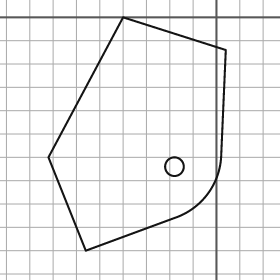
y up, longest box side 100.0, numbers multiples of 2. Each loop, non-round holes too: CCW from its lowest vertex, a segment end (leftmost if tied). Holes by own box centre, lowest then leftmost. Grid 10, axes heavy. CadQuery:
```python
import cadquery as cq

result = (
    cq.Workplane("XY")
    .moveTo(-56.0, -100.0)
    .lineTo(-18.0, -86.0)
    .threePointArc((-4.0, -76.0), (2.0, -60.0))
    .lineTo(4.0, -14.0)
    .lineTo(-40.0, 0.0)
    .lineTo(-72.0, -60.0)
    .close()
    .moveTo(-18.0, -64.0)
    .circle(4.0)
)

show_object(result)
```